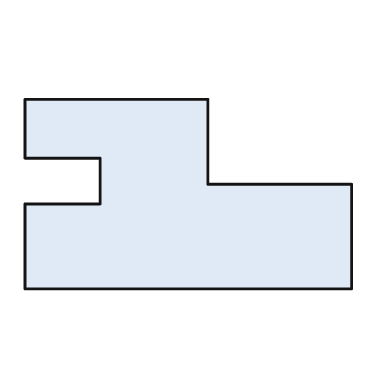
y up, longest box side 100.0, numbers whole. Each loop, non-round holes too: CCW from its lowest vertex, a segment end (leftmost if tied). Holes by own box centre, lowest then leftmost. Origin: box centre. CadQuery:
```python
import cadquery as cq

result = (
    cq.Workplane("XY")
    .moveTo(-50.0, -29.0)
    .lineTo(50.0, -29.0)
    .lineTo(50.0, 3.0)
    .lineTo(6.0, 3.0)
    .lineTo(6.0, 29.0)
    .lineTo(-50.0, 29.0)
    .lineTo(-50.0, 11.0)
    .lineTo(-27.0, 11.0)
    .lineTo(-27.0, -3.0)
    .lineTo(-50.0, -3.0)
    .close()
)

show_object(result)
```